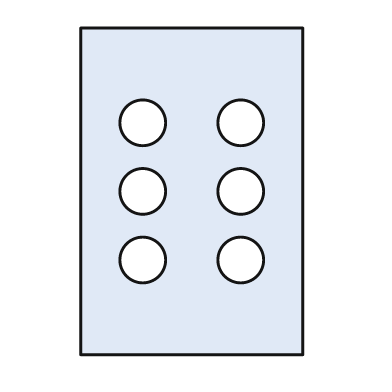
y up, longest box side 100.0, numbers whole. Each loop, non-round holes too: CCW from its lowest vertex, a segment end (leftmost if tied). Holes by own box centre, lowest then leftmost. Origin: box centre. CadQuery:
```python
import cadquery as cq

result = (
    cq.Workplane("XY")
    .moveTo(-34.0, -50.0)
    .lineTo(34.0, -50.0)
    .lineTo(34.0, 50.0)
    .lineTo(-34.0, 50.0)
    .close()
    .moveTo(-15.0, -21.0)
    .circle(7.0)
    .moveTo(15.0, -21.0)
    .circle(7.0)
    .moveTo(-15.0, 0.0)
    .circle(7.0)
    .moveTo(15.0, 0.0)
    .circle(7.0)
    .moveTo(-15.0, 21.0)
    .circle(7.0)
    .moveTo(15.0, 21.0)
    .circle(7.0)
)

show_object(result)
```